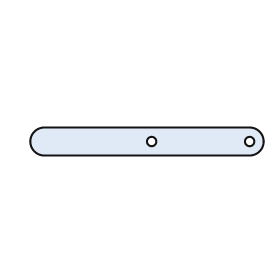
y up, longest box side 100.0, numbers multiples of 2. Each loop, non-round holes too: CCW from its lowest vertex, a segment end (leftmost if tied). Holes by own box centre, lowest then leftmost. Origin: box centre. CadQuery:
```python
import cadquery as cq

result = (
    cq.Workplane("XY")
    .moveTo(-44.0, -6.0)
    .lineTo(44.0, -6.0)
    .threePointArc((50.0, 0.0), (44.0, 6.0))
    .lineTo(-44.0, 6.0)
    .threePointArc((-50.0, 0.0), (-44.0, -6.0))
    .close()
    .moveTo(2.0, 0.0)
    .circle(2.0)
    .moveTo(44.0, 0.0)
    .circle(2.0)
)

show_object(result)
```